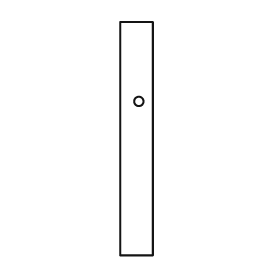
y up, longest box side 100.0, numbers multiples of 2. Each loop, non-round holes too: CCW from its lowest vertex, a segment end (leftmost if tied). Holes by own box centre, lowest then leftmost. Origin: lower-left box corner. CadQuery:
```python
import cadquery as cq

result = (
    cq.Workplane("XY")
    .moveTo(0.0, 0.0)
    .lineTo(14.0, 0.0)
    .lineTo(14.0, 100.0)
    .lineTo(0.0, 100.0)
    .close()
    .moveTo(8.0, 66.0)
    .circle(2.0)
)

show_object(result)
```